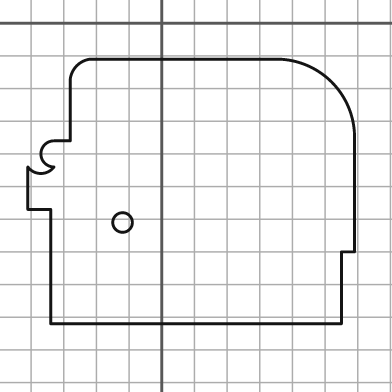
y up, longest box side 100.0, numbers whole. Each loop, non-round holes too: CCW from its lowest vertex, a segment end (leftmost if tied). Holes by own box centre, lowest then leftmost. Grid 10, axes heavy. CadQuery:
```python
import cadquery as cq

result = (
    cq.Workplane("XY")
    .moveTo(-34.0, -92.0)
    .lineTo(55.0, -92.0)
    .lineTo(55.0, -70.0)
    .lineTo(59.0, -70.0)
    .lineTo(59.0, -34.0)
    .threePointArc((52.0, -18.0), (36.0, -11.0))
    .lineTo(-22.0, -11.0)
    .threePointArc((-26.0, -13.0), (-28.0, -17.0))
    .lineTo(-28.0, -36.0)
    .lineTo(-33.0, -36.0)
    .threePointArc((-37.0, -40.0), (-33.0, -44.0))
    .threePointArc((-37.0, -46.0), (-41.0, -44.0))
    .lineTo(-41.0, -57.0)
    .lineTo(-34.0, -57.0)
    .close()
    .moveTo(-12.0, -61.0)
    .circle(3.0)
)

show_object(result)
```